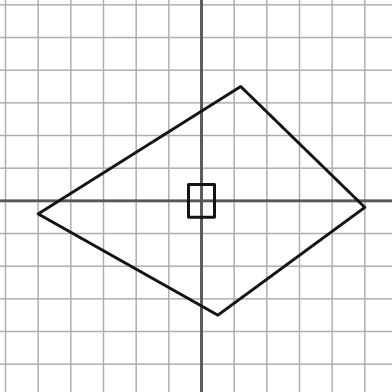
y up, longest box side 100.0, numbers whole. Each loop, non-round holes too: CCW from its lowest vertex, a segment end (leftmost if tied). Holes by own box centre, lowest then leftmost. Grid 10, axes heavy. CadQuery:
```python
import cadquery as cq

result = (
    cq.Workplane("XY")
    .moveTo(5.0, -35.0)
    .lineTo(50.0, -2.0)
    .lineTo(12.0, 35.0)
    .lineTo(-50.0, -4.0)
    .close()
    .moveTo(-4.0, -5.0)
    .lineTo(4.0, -5.0)
    .lineTo(4.0, 5.0)
    .lineTo(-4.0, 5.0)
    .close()
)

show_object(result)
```